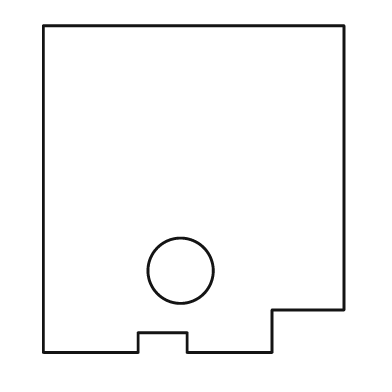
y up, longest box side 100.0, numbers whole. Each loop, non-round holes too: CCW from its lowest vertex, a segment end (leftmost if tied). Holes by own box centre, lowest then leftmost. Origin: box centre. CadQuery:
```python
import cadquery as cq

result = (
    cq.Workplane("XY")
    .moveTo(-46.0, -50.0)
    .lineTo(-17.0, -50.0)
    .lineTo(-17.0, -44.0)
    .lineTo(-2.0, -44.0)
    .lineTo(-2.0, -50.0)
    .lineTo(24.0, -50.0)
    .lineTo(24.0, -37.0)
    .lineTo(46.0, -37.0)
    .lineTo(46.0, 50.0)
    .lineTo(-46.0, 50.0)
    .close()
    .moveTo(-4.0, -25.0)
    .circle(10.0)
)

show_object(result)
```